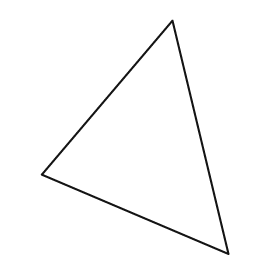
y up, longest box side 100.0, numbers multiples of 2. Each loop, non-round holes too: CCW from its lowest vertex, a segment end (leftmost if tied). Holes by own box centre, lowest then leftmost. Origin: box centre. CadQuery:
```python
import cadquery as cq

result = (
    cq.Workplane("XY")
    .moveTo(40.0, -50.0)
    .lineTo(16.0, 50.0)
    .lineTo(-40.0, -16.0)
    .close()
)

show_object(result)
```